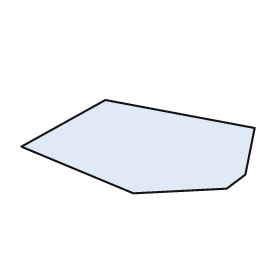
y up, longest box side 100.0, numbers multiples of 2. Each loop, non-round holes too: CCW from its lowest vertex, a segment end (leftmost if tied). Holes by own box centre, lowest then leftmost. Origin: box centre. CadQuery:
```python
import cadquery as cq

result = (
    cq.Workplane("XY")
    .moveTo(-2.0, -20.0)
    .lineTo(38.0, -18.0)
    .lineTo(46.0, -12.0)
    .lineTo(50.0, 8.0)
    .lineTo(-14.0, 20.0)
    .lineTo(-50.0, 0.0)
    .close()
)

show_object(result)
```